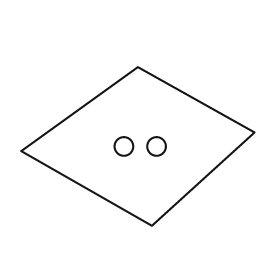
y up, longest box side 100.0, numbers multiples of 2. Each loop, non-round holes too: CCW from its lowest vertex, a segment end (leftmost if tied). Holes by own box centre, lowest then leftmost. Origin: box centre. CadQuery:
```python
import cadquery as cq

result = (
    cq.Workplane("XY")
    .moveTo(6.0, -34.0)
    .lineTo(50.0, 6.0)
    .lineTo(0.0, 34.0)
    .lineTo(-50.0, -2.0)
    .close()
    .moveTo(-6.0, 0.0)
    .circle(4.0)
    .moveTo(8.0, 0.0)
    .circle(4.0)
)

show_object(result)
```